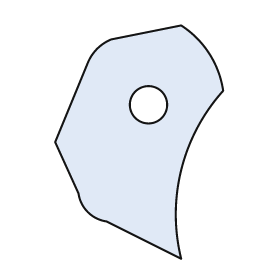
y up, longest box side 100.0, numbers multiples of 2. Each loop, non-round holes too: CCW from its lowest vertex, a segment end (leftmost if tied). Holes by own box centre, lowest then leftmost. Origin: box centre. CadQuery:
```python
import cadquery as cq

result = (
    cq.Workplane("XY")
    .moveTo(18.0, -50.0)
    .threePointArc((18.0, -12.0), (36.0, 22.0))
    .threePointArc((30.0, 38.0), (18.0, 50.0))
    .lineTo(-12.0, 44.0)
    .threePointArc((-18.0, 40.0), (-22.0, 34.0))
    .lineTo(-36.0, 0.0)
    .lineTo(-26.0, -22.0)
    .threePointArc((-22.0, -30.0), (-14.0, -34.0))
    .close()
    .moveTo(4.0, 16.0)
    .circle(8.0)
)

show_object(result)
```